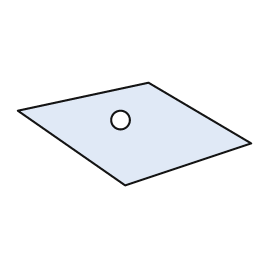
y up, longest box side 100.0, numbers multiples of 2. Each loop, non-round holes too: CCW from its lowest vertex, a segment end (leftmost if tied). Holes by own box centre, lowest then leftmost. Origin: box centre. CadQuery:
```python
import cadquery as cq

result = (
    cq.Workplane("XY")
    .moveTo(-4.0, -22.0)
    .lineTo(50.0, -4.0)
    .lineTo(6.0, 22.0)
    .lineTo(-50.0, 10.0)
    .close()
    .moveTo(-6.0, 6.0)
    .circle(4.0)
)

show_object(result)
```